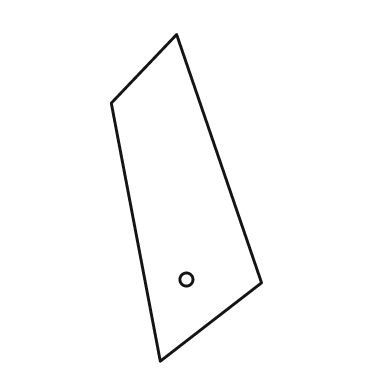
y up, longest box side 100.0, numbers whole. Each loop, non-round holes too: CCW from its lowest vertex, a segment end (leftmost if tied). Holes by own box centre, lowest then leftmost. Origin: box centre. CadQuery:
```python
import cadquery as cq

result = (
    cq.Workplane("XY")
    .moveTo(-8.0, -50.0)
    .lineTo(23.0, -26.0)
    .lineTo(-3.0, 50.0)
    .lineTo(-23.0, 29.0)
    .close()
    .moveTo(0.0, -25.0)
    .circle(2.0)
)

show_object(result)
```